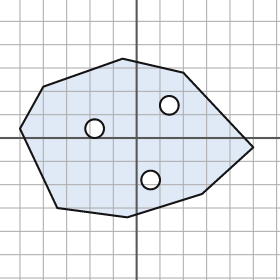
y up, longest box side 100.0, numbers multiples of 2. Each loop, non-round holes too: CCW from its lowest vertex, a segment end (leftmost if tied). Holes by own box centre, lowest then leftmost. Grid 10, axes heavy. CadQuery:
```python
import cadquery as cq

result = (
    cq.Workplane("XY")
    .moveTo(-4.0, -34.0)
    .lineTo(28.0, -24.0)
    .lineTo(50.0, -4.0)
    .lineTo(20.0, 28.0)
    .lineTo(-6.0, 34.0)
    .lineTo(-40.0, 22.0)
    .lineTo(-50.0, 4.0)
    .lineTo(-34.0, -30.0)
    .close()
    .moveTo(6.0, -18.0)
    .circle(4.0)
    .moveTo(-18.0, 4.0)
    .circle(4.0)
    .moveTo(14.0, 14.0)
    .circle(4.0)
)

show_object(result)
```